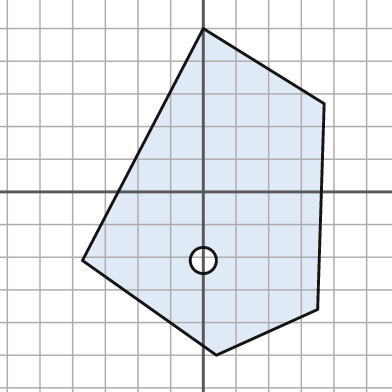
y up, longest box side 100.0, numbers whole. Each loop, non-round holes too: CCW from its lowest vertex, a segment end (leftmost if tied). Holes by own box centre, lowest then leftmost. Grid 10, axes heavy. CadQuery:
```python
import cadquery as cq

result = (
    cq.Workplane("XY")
    .moveTo(4.0, -50.0)
    .lineTo(35.0, -36.0)
    .lineTo(37.0, 27.0)
    .lineTo(0.0, 50.0)
    .lineTo(-37.0, -21.0)
    .close()
    .moveTo(0.0, -21.0)
    .circle(4.0)
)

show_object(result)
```